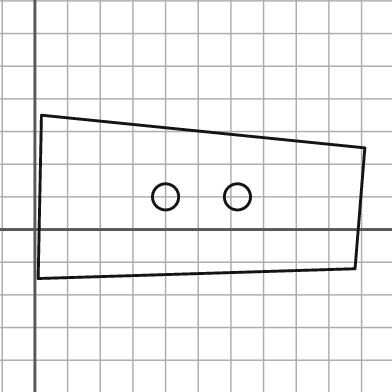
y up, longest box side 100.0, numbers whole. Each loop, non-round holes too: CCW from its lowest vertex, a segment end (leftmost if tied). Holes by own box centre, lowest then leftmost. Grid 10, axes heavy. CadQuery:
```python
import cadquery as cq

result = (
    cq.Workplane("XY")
    .moveTo(1.0, -15.0)
    .lineTo(98.0, -12.0)
    .lineTo(101.0, 25.0)
    .lineTo(2.0, 35.0)
    .close()
    .moveTo(40.0, 10.0)
    .circle(4.0)
    .moveTo(62.0, 10.0)
    .circle(4.0)
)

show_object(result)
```